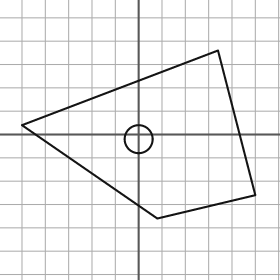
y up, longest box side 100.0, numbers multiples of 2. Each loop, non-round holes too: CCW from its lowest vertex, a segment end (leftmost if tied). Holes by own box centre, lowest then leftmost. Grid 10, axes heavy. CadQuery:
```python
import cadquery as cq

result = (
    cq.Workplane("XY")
    .moveTo(8.0, -36.0)
    .lineTo(50.0, -26.0)
    .lineTo(34.0, 36.0)
    .lineTo(-50.0, 4.0)
    .close()
    .moveTo(0.0, -2.0)
    .circle(6.0)
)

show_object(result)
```